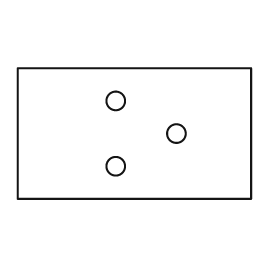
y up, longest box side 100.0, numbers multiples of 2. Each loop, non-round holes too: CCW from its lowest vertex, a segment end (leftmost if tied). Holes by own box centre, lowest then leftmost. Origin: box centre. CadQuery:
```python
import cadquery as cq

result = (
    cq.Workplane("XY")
    .moveTo(-50.0, -28.0)
    .lineTo(50.0, -28.0)
    .lineTo(50.0, 28.0)
    .lineTo(-50.0, 28.0)
    .close()
    .moveTo(-8.0, -14.0)
    .circle(4.0)
    .moveTo(18.0, 0.0)
    .circle(4.0)
    .moveTo(-8.0, 14.0)
    .circle(4.0)
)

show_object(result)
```